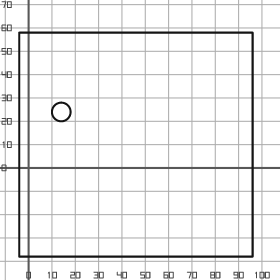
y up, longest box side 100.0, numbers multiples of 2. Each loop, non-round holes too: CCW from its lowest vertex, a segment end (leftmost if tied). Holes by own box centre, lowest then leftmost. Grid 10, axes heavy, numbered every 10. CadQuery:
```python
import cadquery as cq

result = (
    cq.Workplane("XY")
    .moveTo(-4.0, -38.0)
    .lineTo(96.0, -38.0)
    .lineTo(96.0, 58.0)
    .lineTo(-4.0, 58.0)
    .close()
    .moveTo(14.0, 24.0)
    .circle(4.0)
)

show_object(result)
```